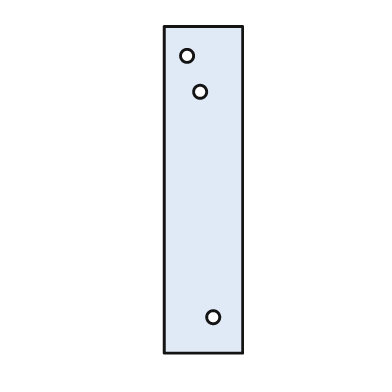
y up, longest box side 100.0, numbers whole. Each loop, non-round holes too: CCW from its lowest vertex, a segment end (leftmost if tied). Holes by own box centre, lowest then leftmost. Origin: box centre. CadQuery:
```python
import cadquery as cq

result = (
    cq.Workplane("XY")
    .moveTo(-12.0, -50.0)
    .lineTo(12.0, -50.0)
    .lineTo(12.0, 50.0)
    .lineTo(-12.0, 50.0)
    .close()
    .moveTo(3.0, -39.0)
    .circle(2.0)
    .moveTo(-1.0, 30.0)
    .circle(2.0)
    .moveTo(-5.0, 41.0)
    .circle(2.0)
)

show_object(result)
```